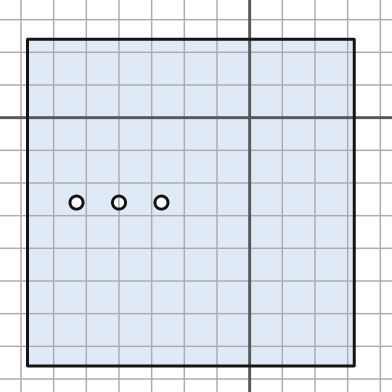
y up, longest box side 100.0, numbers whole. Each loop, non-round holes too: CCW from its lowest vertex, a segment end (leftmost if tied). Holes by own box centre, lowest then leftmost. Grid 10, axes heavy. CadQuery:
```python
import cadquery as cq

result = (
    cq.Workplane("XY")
    .moveTo(-68.0, -76.0)
    .lineTo(32.0, -76.0)
    .lineTo(32.0, 24.0)
    .lineTo(-68.0, 24.0)
    .close()
    .moveTo(-53.0, -26.0)
    .circle(2.0)
    .moveTo(-40.0, -26.0)
    .circle(2.0)
    .moveTo(-27.0, -26.0)
    .circle(2.0)
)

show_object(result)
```